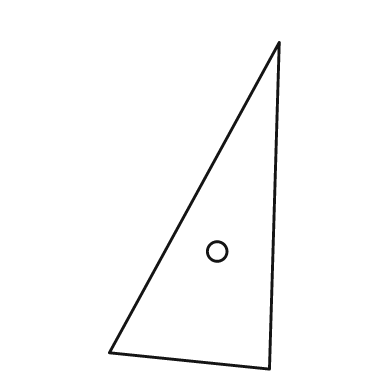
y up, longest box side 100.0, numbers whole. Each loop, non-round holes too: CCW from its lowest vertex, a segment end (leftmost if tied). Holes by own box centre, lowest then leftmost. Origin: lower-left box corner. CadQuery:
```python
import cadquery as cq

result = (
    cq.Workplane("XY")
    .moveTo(49.0, 0.0)
    .lineTo(52.0, 100.0)
    .lineTo(0.0, 5.0)
    .close()
    .moveTo(33.0, 36.0)
    .circle(3.0)
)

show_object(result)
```